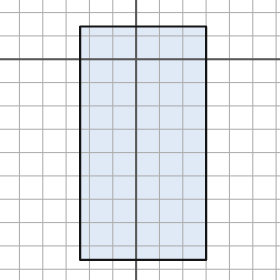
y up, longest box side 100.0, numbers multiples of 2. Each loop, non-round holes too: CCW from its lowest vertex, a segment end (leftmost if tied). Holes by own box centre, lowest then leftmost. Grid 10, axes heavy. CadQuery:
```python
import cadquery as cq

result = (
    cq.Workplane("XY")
    .moveTo(-24.0, -86.0)
    .lineTo(30.0, -86.0)
    .lineTo(30.0, 14.0)
    .lineTo(-24.0, 14.0)
    .close()
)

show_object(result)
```